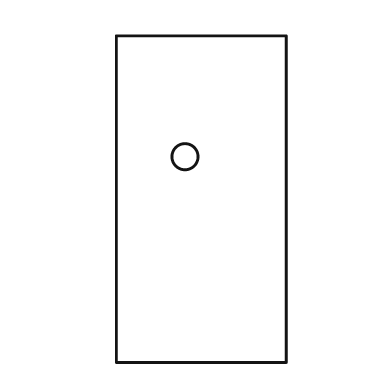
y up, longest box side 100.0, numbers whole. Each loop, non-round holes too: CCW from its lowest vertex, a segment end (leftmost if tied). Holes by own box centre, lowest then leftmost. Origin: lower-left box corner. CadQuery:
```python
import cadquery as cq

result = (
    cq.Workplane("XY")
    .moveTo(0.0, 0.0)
    .lineTo(52.0, 0.0)
    .lineTo(52.0, 100.0)
    .lineTo(0.0, 100.0)
    .close()
    .moveTo(21.0, 63.0)
    .circle(4.0)
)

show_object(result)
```